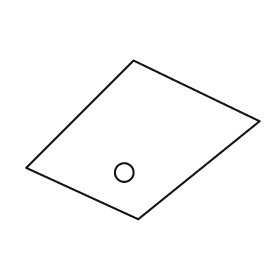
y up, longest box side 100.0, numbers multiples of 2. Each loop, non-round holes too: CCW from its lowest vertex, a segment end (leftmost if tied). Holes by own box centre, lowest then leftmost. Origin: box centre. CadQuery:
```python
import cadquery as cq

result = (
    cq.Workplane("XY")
    .moveTo(-2.0, -34.0)
    .lineTo(50.0, 8.0)
    .lineTo(-4.0, 34.0)
    .lineTo(-50.0, -12.0)
    .close()
    .moveTo(-8.0, -14.0)
    .circle(4.0)
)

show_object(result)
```